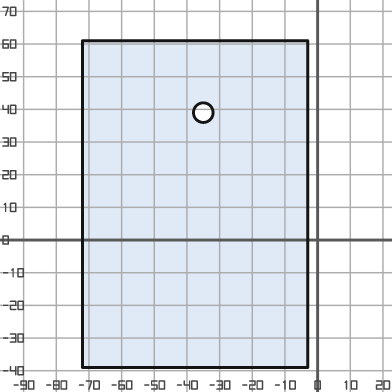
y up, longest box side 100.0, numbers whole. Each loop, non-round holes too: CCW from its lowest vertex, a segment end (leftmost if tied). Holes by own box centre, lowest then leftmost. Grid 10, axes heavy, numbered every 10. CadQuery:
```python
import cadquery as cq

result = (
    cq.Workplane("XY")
    .moveTo(-72.0, -39.0)
    .lineTo(-3.0, -39.0)
    .lineTo(-3.0, 61.0)
    .lineTo(-72.0, 61.0)
    .close()
    .moveTo(-35.0, 39.0)
    .circle(3.0)
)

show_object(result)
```